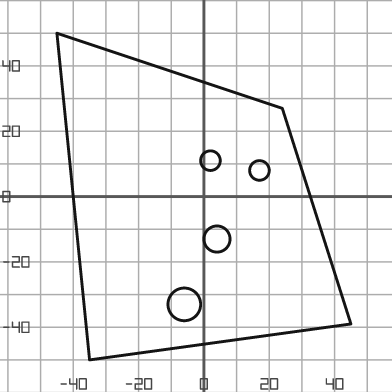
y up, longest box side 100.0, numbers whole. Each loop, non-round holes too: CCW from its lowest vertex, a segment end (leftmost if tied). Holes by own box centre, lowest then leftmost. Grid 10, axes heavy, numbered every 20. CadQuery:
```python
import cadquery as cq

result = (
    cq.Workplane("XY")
    .moveTo(-35.0, -50.0)
    .lineTo(45.0, -39.0)
    .lineTo(24.0, 27.0)
    .lineTo(-45.0, 50.0)
    .close()
    .moveTo(-6.0, -33.0)
    .circle(5.0)
    .moveTo(4.0, -13.0)
    .circle(4.0)
    .moveTo(17.0, 8.0)
    .circle(3.0)
    .moveTo(2.0, 11.0)
    .circle(3.0)
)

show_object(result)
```